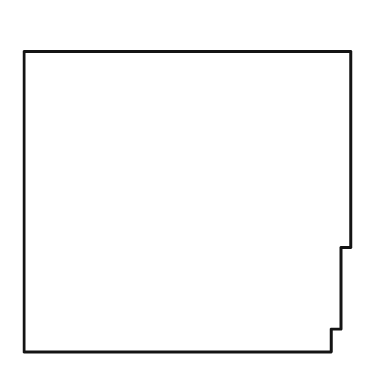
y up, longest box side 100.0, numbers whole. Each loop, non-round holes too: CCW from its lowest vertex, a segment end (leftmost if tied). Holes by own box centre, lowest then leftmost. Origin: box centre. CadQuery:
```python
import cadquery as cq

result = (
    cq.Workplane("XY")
    .moveTo(-50.0, -46.0)
    .lineTo(44.0, -46.0)
    .lineTo(44.0, -39.0)
    .lineTo(47.0, -39.0)
    .lineTo(47.0, -14.0)
    .lineTo(50.0, -14.0)
    .lineTo(50.0, 46.0)
    .lineTo(-50.0, 46.0)
    .close()
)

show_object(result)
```